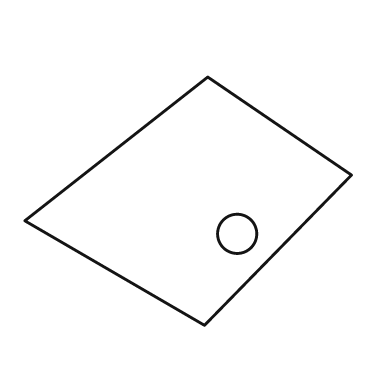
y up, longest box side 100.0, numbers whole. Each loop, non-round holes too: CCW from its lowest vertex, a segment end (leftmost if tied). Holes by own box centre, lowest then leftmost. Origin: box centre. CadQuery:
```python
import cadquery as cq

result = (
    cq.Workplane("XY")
    .moveTo(5.0, -38.0)
    .lineTo(50.0, 8.0)
    .lineTo(6.0, 38.0)
    .lineTo(-50.0, -6.0)
    .close()
    .moveTo(15.0, -10.0)
    .circle(6.0)
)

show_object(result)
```